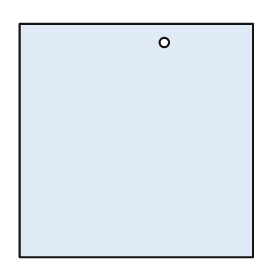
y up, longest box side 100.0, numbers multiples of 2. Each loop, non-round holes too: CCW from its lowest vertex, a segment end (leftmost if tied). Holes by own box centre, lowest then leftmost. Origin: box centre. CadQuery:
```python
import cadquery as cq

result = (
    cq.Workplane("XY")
    .moveTo(-50.0, -50.0)
    .lineTo(50.0, -50.0)
    .lineTo(50.0, 50.0)
    .lineTo(-50.0, 50.0)
    .close()
    .moveTo(12.0, 42.0)
    .circle(2.0)
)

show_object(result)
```